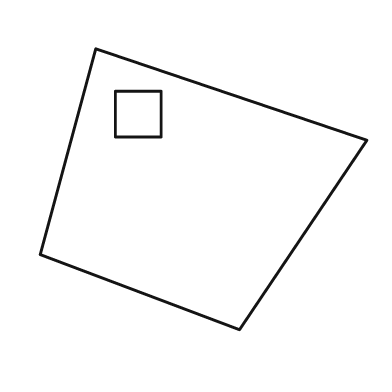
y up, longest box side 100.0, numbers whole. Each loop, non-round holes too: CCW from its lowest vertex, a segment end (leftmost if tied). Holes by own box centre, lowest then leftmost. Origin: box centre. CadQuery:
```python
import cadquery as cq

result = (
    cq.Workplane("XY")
    .moveTo(11.0, -43.0)
    .lineTo(50.0, 15.0)
    .lineTo(-33.0, 43.0)
    .lineTo(-50.0, -20.0)
    .close()
    .moveTo(-27.0, 16.0)
    .lineTo(-13.0, 16.0)
    .lineTo(-13.0, 30.0)
    .lineTo(-27.0, 30.0)
    .close()
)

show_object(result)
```